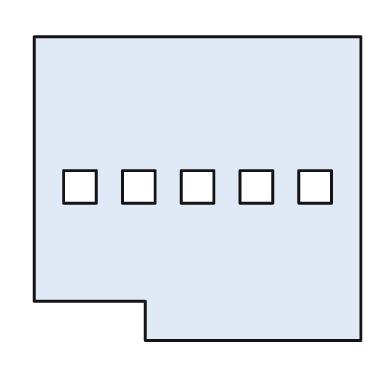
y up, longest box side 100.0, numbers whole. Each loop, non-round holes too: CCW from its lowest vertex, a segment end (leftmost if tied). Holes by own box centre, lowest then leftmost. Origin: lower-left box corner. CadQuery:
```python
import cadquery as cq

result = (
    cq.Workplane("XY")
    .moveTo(34.0, 0.0)
    .lineTo(100.0, 0.0)
    .lineTo(100.0, 93.0)
    .lineTo(0.0, 93.0)
    .lineTo(0.0, 12.0)
    .lineTo(34.0, 12.0)
    .close()
    .moveTo(9.0, 42.0)
    .lineTo(19.0, 42.0)
    .lineTo(19.0, 52.0)
    .lineTo(9.0, 52.0)
    .close()
    .moveTo(27.0, 42.0)
    .lineTo(37.0, 42.0)
    .lineTo(37.0, 52.0)
    .lineTo(27.0, 52.0)
    .close()
    .moveTo(45.0, 42.0)
    .lineTo(55.0, 42.0)
    .lineTo(55.0, 52.0)
    .lineTo(45.0, 52.0)
    .close()
    .moveTo(63.0, 42.0)
    .lineTo(73.0, 42.0)
    .lineTo(73.0, 52.0)
    .lineTo(63.0, 52.0)
    .close()
    .moveTo(81.0, 42.0)
    .lineTo(91.0, 42.0)
    .lineTo(91.0, 52.0)
    .lineTo(81.0, 52.0)
    .close()
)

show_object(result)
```